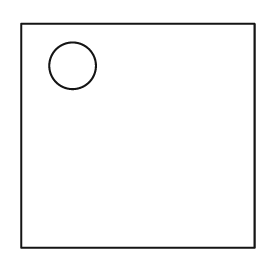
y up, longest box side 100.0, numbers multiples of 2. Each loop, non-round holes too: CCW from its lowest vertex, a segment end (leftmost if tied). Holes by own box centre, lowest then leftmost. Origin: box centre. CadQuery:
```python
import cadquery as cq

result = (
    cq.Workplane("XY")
    .moveTo(-50.0, -48.0)
    .lineTo(50.0, -48.0)
    .lineTo(50.0, 48.0)
    .lineTo(-50.0, 48.0)
    .close()
    .moveTo(-28.0, 30.0)
    .circle(10.0)
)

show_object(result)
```